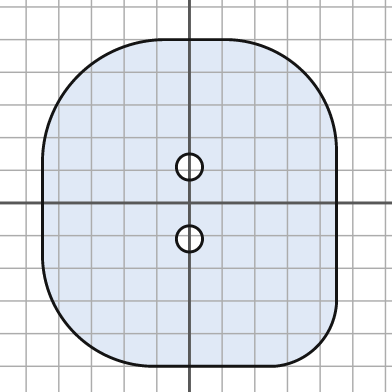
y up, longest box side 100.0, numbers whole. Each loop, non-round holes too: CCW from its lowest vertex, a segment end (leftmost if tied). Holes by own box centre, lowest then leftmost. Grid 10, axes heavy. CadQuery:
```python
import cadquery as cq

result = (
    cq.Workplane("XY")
    .moveTo(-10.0, -50.0)
    .lineTo(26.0, -50.0)
    .threePointArc((39.0, -44.0), (45.0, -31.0))
    .lineTo(45.0, 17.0)
    .threePointArc((35.0, 40.0), (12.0, 50.0))
    .lineTo(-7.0, 50.0)
    .threePointArc((-34.0, 39.0), (-45.0, 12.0))
    .lineTo(-45.0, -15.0)
    .threePointArc((-35.0, -40.0), (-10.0, -50.0))
    .close()
    .moveTo(0.0, -11.0)
    .circle(4.0)
    .moveTo(0.0, 11.0)
    .circle(4.0)
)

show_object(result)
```